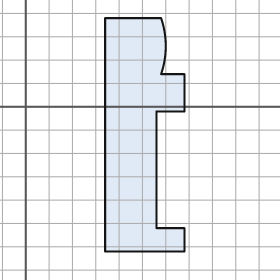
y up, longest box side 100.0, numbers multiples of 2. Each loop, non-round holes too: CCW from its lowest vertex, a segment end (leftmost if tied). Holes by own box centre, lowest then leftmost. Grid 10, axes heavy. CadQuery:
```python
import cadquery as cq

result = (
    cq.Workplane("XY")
    .moveTo(34.0, -62.0)
    .lineTo(68.0, -62.0)
    .lineTo(68.0, -52.0)
    .lineTo(56.0, -52.0)
    .lineTo(56.0, -2.0)
    .lineTo(68.0, -2.0)
    .lineTo(68.0, 14.0)
    .lineTo(58.0, 14.0)
    .threePointArc((60.0, 26.0), (58.0, 38.0))
    .lineTo(34.0, 38.0)
    .close()
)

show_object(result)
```